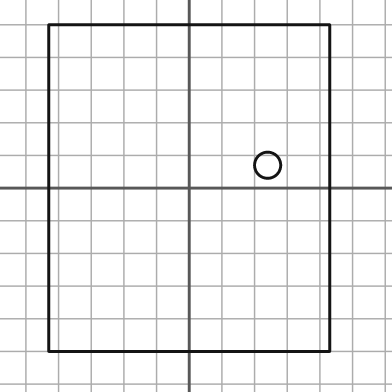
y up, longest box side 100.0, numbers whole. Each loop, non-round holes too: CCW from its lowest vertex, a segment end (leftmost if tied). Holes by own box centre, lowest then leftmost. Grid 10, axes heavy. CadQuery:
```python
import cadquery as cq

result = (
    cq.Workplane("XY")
    .moveTo(-43.0, -50.0)
    .lineTo(43.0, -50.0)
    .lineTo(43.0, 50.0)
    .lineTo(-43.0, 50.0)
    .close()
    .moveTo(24.0, 7.0)
    .circle(4.0)
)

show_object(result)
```